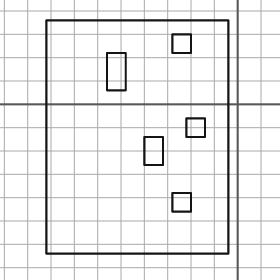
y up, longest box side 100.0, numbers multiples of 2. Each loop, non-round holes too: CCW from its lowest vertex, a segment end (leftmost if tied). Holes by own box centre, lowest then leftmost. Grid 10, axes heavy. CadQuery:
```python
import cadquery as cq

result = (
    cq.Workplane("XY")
    .moveTo(-82.0, -64.0)
    .lineTo(-4.0, -64.0)
    .lineTo(-4.0, 36.0)
    .lineTo(-82.0, 36.0)
    .close()
    .moveTo(-28.0, -46.0)
    .lineTo(-20.0, -46.0)
    .lineTo(-20.0, -38.0)
    .lineTo(-28.0, -38.0)
    .close()
    .moveTo(-40.0, -26.0)
    .lineTo(-32.0, -26.0)
    .lineTo(-32.0, -14.0)
    .lineTo(-40.0, -14.0)
    .close()
    .moveTo(-22.0, -14.0)
    .lineTo(-14.0, -14.0)
    .lineTo(-14.0, -6.0)
    .lineTo(-22.0, -6.0)
    .close()
    .moveTo(-56.0, 6.0)
    .lineTo(-48.0, 6.0)
    .lineTo(-48.0, 22.0)
    .lineTo(-56.0, 22.0)
    .close()
    .moveTo(-28.0, 22.0)
    .lineTo(-20.0, 22.0)
    .lineTo(-20.0, 30.0)
    .lineTo(-28.0, 30.0)
    .close()
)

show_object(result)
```